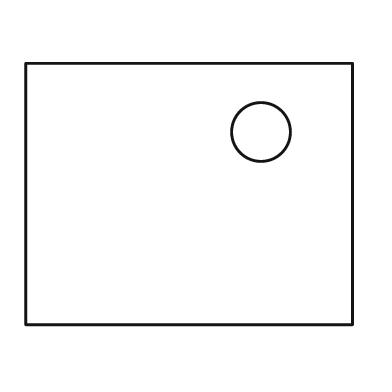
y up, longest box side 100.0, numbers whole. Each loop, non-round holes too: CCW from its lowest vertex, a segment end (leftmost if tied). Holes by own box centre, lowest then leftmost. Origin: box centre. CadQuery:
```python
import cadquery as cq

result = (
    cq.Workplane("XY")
    .moveTo(-50.0, -40.0)
    .lineTo(50.0, -40.0)
    .lineTo(50.0, 40.0)
    .lineTo(-50.0, 40.0)
    .close()
    .moveTo(22.0, 19.0)
    .circle(9.0)
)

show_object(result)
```